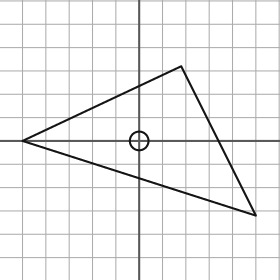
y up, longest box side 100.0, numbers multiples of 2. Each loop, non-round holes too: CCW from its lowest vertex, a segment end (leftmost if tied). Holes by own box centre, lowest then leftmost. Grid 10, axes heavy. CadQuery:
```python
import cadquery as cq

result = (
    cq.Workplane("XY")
    .moveTo(50.0, -32.0)
    .lineTo(18.0, 32.0)
    .lineTo(-50.0, 0.0)
    .close()
    .moveTo(0.0, 0.0)
    .circle(4.0)
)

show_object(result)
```